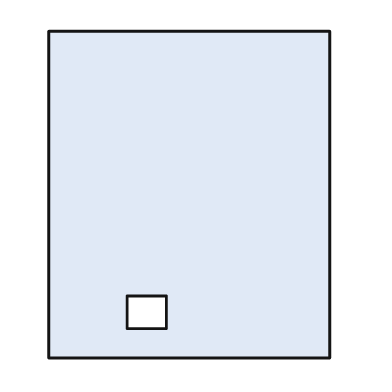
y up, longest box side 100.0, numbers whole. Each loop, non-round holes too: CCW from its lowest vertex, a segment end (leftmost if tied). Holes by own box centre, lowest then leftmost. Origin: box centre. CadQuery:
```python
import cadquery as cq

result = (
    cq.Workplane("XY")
    .moveTo(-43.0, -50.0)
    .lineTo(43.0, -50.0)
    .lineTo(43.0, 50.0)
    .lineTo(-43.0, 50.0)
    .close()
    .moveTo(-19.0, -41.0)
    .lineTo(-7.0, -41.0)
    .lineTo(-7.0, -31.0)
    .lineTo(-19.0, -31.0)
    .close()
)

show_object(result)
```